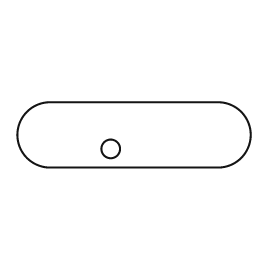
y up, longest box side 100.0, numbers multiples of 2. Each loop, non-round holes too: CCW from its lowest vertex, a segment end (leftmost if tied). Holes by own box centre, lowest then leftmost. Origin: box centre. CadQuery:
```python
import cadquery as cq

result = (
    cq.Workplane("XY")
    .moveTo(-36.0, -14.0)
    .lineTo(36.0, -14.0)
    .threePointArc((50.0, 0.0), (36.0, 14.0))
    .lineTo(-36.0, 14.0)
    .threePointArc((-50.0, 0.0), (-36.0, -14.0))
    .close()
    .moveTo(-10.0, -6.0)
    .circle(4.0)
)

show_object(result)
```